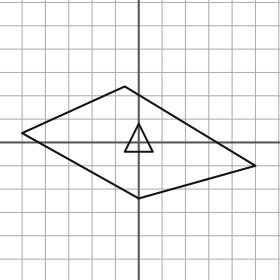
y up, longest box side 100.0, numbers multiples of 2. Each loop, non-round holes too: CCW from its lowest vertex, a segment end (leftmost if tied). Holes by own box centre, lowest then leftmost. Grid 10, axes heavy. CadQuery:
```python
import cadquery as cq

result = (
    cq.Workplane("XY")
    .moveTo(0.0, -24.0)
    .lineTo(50.0, -10.0)
    .lineTo(-6.0, 24.0)
    .lineTo(-50.0, 4.0)
    .close()
    .moveTo(-6.0, -4.0)
    .lineTo(6.0, -4.0)
    .lineTo(0.0, 8.0)
    .close()
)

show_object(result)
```